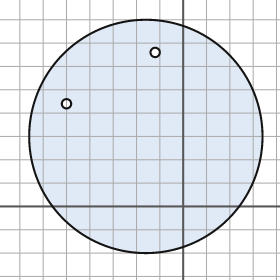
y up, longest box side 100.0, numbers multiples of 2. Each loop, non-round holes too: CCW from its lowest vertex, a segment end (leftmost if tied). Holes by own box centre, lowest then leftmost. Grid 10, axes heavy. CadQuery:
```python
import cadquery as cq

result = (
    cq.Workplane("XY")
    .moveTo(-16.0, 30.0)
    .circle(50.0)
    .moveTo(-50.0, 44.0)
    .circle(2.0)
    .moveTo(-12.0, 66.0)
    .circle(2.0)
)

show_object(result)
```